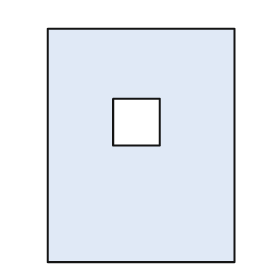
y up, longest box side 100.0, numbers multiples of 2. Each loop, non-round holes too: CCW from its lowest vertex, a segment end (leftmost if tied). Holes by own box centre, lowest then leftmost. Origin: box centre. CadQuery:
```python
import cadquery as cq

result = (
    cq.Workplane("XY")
    .moveTo(-40.0, -50.0)
    .lineTo(40.0, -50.0)
    .lineTo(40.0, 50.0)
    .lineTo(-40.0, 50.0)
    .close()
    .moveTo(-12.0, 0.0)
    .lineTo(8.0, 0.0)
    .lineTo(8.0, 20.0)
    .lineTo(-12.0, 20.0)
    .close()
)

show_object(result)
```